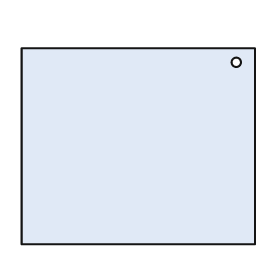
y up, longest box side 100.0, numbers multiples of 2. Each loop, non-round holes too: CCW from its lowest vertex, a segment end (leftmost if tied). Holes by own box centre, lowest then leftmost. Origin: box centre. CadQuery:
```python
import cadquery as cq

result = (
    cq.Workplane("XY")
    .moveTo(-50.0, -42.0)
    .lineTo(50.0, -42.0)
    .lineTo(50.0, 42.0)
    .lineTo(-50.0, 42.0)
    .close()
    .moveTo(42.0, 36.0)
    .circle(2.0)
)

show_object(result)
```